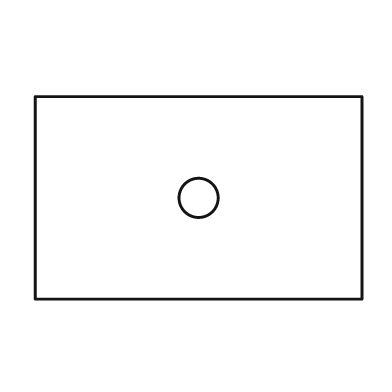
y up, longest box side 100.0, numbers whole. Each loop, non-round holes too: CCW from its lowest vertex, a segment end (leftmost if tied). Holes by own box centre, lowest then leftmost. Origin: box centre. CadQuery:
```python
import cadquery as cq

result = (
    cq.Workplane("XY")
    .moveTo(-50.0, -31.0)
    .lineTo(50.0, -31.0)
    .lineTo(50.0, 31.0)
    .lineTo(-50.0, 31.0)
    .close()
    .moveTo(0.0, 0.0)
    .circle(6.0)
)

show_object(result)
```